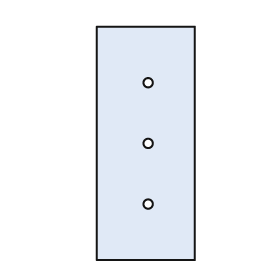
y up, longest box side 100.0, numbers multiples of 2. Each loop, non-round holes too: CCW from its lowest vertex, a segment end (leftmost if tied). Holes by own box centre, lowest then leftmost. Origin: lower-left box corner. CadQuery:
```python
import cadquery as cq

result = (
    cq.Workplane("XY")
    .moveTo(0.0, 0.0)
    .lineTo(42.0, 0.0)
    .lineTo(42.0, 100.0)
    .lineTo(0.0, 100.0)
    .close()
    .moveTo(22.0, 24.0)
    .circle(2.0)
    .moveTo(22.0, 50.0)
    .circle(2.0)
    .moveTo(22.0, 76.0)
    .circle(2.0)
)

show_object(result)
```